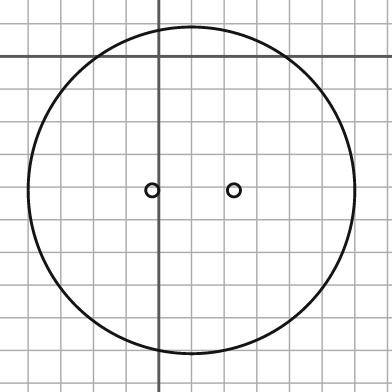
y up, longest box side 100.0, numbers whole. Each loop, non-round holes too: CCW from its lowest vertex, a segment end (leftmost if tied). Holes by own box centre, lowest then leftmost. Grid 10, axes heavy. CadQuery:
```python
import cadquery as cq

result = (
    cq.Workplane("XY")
    .moveTo(10.0, -41.0)
    .circle(50.0)
    .moveTo(-2.0, -41.0)
    .circle(2.0)
    .moveTo(23.0, -41.0)
    .circle(2.0)
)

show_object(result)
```